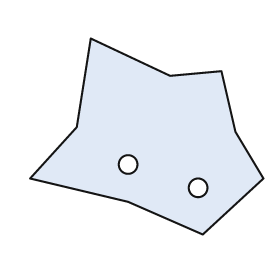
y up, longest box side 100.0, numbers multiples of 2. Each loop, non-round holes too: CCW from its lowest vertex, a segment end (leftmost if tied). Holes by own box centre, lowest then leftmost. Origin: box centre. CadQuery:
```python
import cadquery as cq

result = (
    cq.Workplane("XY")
    .moveTo(24.0, -42.0)
    .lineTo(50.0, -18.0)
    .lineTo(38.0, 2.0)
    .lineTo(32.0, 28.0)
    .lineTo(10.0, 26.0)
    .lineTo(-24.0, 42.0)
    .lineTo(-30.0, 4.0)
    .lineTo(-50.0, -18.0)
    .lineTo(-8.0, -28.0)
    .close()
    .moveTo(22.0, -22.0)
    .circle(4.0)
    .moveTo(-8.0, -12.0)
    .circle(4.0)
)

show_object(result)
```